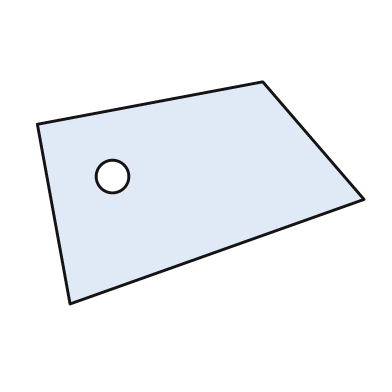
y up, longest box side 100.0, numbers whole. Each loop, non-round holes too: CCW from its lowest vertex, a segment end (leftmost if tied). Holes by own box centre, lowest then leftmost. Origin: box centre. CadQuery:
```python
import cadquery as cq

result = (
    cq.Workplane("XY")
    .moveTo(-40.0, -34.0)
    .lineTo(50.0, -2.0)
    .lineTo(19.0, 34.0)
    .lineTo(-50.0, 21.0)
    .close()
    .moveTo(-27.0, 5.0)
    .circle(5.0)
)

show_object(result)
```